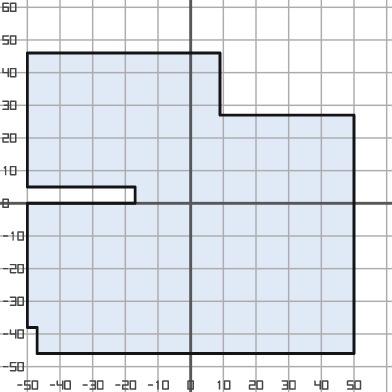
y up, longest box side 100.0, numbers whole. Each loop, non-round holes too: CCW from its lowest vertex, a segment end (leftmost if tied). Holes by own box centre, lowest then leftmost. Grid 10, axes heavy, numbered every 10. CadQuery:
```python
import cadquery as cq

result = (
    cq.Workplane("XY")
    .moveTo(-47.0, -46.0)
    .lineTo(50.0, -46.0)
    .lineTo(50.0, 27.0)
    .lineTo(9.0, 27.0)
    .lineTo(9.0, 46.0)
    .lineTo(-50.0, 46.0)
    .lineTo(-50.0, 5.0)
    .lineTo(-17.0, 5.0)
    .lineTo(-17.0, 0.0)
    .lineTo(-50.0, 0.0)
    .lineTo(-50.0, -38.0)
    .lineTo(-47.0, -38.0)
    .close()
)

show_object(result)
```